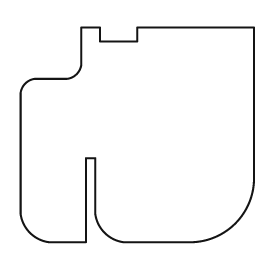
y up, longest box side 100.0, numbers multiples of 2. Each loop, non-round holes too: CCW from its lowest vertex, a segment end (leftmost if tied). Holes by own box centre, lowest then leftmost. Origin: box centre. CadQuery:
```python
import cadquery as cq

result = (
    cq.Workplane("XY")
    .moveTo(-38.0, -46.0)
    .lineTo(-22.0, -46.0)
    .lineTo(-22.0, -10.0)
    .lineTo(-18.0, -10.0)
    .lineTo(-18.0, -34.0)
    .threePointArc((-14.0, -42.0), (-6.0, -46.0))
    .lineTo(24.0, -46.0)
    .threePointArc((42.0, -38.0), (50.0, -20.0))
    .lineTo(50.0, 46.0)
    .lineTo(0.0, 46.0)
    .lineTo(0.0, 40.0)
    .lineTo(-16.0, 40.0)
    .lineTo(-16.0, 46.0)
    .lineTo(-24.0, 46.0)
    .lineTo(-24.0, 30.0)
    .threePointArc((-26.0, 26.0), (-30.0, 24.0))
    .lineTo(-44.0, 24.0)
    .threePointArc((-48.0, 22.0), (-50.0, 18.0))
    .lineTo(-50.0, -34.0)
    .threePointArc((-46.0, -42.0), (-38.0, -46.0))
    .close()
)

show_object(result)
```